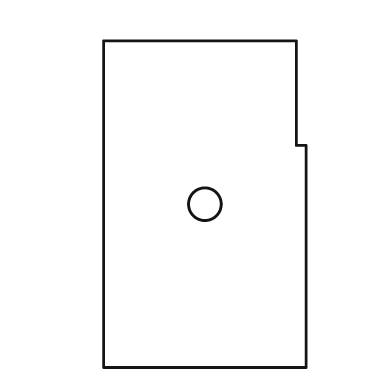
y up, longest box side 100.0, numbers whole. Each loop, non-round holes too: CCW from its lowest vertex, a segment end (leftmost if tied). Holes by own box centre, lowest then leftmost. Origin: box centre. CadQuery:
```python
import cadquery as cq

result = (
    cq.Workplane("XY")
    .moveTo(-31.0, -50.0)
    .lineTo(31.0, -50.0)
    .lineTo(31.0, 18.0)
    .lineTo(28.0, 18.0)
    .lineTo(28.0, 50.0)
    .lineTo(-31.0, 50.0)
    .close()
    .moveTo(0.0, 0.0)
    .circle(5.0)
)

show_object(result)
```